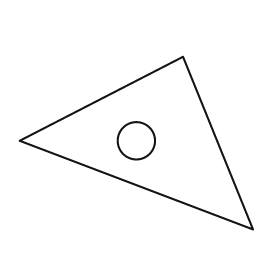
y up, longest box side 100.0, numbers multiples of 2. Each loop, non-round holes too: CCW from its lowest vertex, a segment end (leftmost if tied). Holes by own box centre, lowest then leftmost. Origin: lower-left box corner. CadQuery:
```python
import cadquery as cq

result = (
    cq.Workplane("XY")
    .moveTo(100.0, 0.0)
    .lineTo(70.0, 74.0)
    .lineTo(0.0, 38.0)
    .close()
    .moveTo(50.0, 38.0)
    .circle(8.0)
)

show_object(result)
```